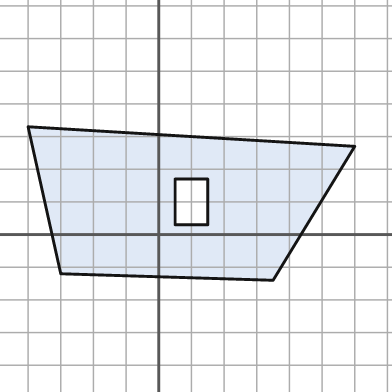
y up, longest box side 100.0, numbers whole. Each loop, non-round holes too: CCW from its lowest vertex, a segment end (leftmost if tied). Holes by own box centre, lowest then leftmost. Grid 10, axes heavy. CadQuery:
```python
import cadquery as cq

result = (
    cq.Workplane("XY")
    .moveTo(35.0, -14.0)
    .lineTo(60.0, 27.0)
    .lineTo(-40.0, 33.0)
    .lineTo(-30.0, -12.0)
    .close()
    .moveTo(5.0, 3.0)
    .lineTo(15.0, 3.0)
    .lineTo(15.0, 17.0)
    .lineTo(5.0, 17.0)
    .close()
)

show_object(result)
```